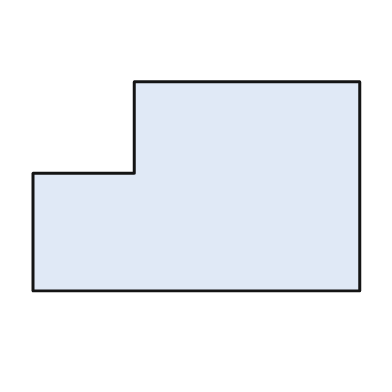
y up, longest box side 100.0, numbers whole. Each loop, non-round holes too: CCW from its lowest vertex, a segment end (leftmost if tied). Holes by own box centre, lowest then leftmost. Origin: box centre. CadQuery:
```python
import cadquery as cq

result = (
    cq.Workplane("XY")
    .moveTo(-50.0, -32.0)
    .lineTo(50.0, -32.0)
    .lineTo(50.0, 32.0)
    .lineTo(-19.0, 32.0)
    .lineTo(-19.0, 4.0)
    .lineTo(-50.0, 4.0)
    .close()
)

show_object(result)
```